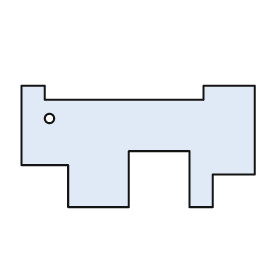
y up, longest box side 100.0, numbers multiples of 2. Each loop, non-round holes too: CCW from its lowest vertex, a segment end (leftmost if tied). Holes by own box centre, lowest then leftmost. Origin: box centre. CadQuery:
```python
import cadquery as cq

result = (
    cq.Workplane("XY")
    .moveTo(-30.0, -26.0)
    .lineTo(-4.0, -26.0)
    .lineTo(-4.0, -2.0)
    .lineTo(22.0, -2.0)
    .lineTo(22.0, -26.0)
    .lineTo(32.0, -26.0)
    .lineTo(32.0, -12.0)
    .lineTo(50.0, -12.0)
    .lineTo(50.0, 26.0)
    .lineTo(28.0, 26.0)
    .lineTo(28.0, 20.0)
    .lineTo(-40.0, 20.0)
    .lineTo(-40.0, 26.0)
    .lineTo(-50.0, 26.0)
    .lineTo(-50.0, -8.0)
    .lineTo(-30.0, -8.0)
    .close()
    .moveTo(-38.0, 12.0)
    .circle(2.0)
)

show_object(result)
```